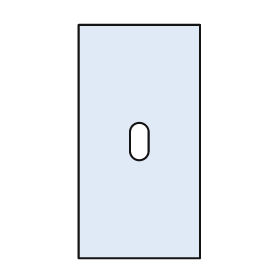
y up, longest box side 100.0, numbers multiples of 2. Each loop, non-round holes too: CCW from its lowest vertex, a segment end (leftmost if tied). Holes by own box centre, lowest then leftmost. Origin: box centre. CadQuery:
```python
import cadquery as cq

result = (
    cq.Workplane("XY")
    .moveTo(-26.0, -50.0)
    .lineTo(26.0, -50.0)
    .lineTo(26.0, 50.0)
    .lineTo(-26.0, 50.0)
    .close()
    .moveTo(-4.0, -4.0)
    .threePointArc((0.0, -8.0), (4.0, -4.0))
    .lineTo(4.0, 4.0)
    .threePointArc((0.0, 8.0), (-4.0, 4.0))
    .close()
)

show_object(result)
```